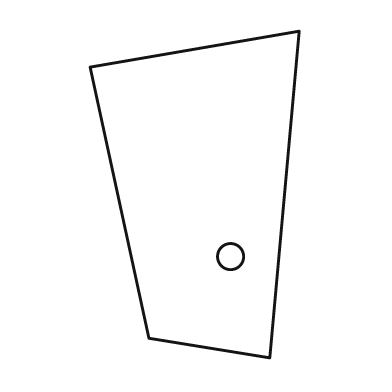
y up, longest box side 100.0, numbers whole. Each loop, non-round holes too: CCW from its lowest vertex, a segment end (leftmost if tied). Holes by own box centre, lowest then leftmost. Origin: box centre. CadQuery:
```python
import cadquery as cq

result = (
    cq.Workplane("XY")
    .moveTo(23.0, -50.0)
    .lineTo(32.0, 50.0)
    .lineTo(-32.0, 39.0)
    .lineTo(-14.0, -44.0)
    .close()
    .moveTo(11.0, -19.0)
    .circle(4.0)
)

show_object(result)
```